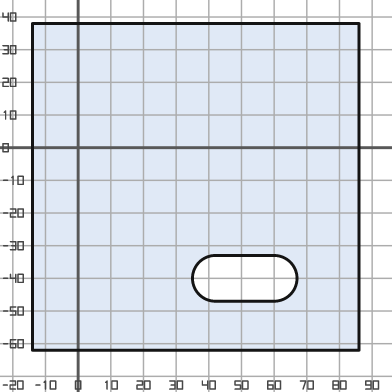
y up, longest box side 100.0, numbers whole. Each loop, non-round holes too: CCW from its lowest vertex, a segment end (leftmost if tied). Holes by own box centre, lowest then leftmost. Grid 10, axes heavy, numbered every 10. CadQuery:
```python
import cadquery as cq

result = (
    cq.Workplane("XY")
    .moveTo(-14.0, -62.0)
    .lineTo(86.0, -62.0)
    .lineTo(86.0, 38.0)
    .lineTo(-14.0, 38.0)
    .close()
    .moveTo(42.0, -47.0)
    .lineTo(60.0, -47.0)
    .threePointArc((67.0, -40.0), (60.0, -33.0))
    .lineTo(42.0, -33.0)
    .threePointArc((35.0, -40.0), (42.0, -47.0))
    .close()
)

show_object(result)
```